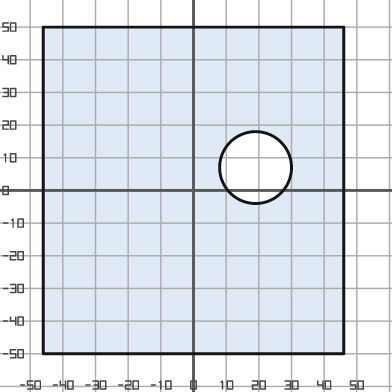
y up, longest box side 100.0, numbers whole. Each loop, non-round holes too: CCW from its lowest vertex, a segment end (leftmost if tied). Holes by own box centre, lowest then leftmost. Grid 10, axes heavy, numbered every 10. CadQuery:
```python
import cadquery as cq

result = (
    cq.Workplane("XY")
    .moveTo(-46.0, -50.0)
    .lineTo(46.0, -50.0)
    .lineTo(46.0, 50.0)
    .lineTo(-46.0, 50.0)
    .close()
    .moveTo(19.0, 7.0)
    .circle(11.0)
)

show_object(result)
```